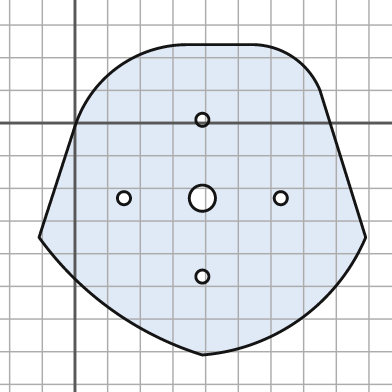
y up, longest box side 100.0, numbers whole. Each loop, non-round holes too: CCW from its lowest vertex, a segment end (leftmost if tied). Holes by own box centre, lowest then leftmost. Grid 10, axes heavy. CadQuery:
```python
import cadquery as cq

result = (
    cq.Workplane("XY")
    .moveTo(39.0, -71.0)
    .threePointArc((69.0, -60.0), (89.0, -35.0))
    .lineTo(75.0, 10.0)
    .threePointArc((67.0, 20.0), (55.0, 24.0))
    .lineTo(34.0, 24.0)
    .threePointArc((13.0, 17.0), (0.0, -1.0))
    .lineTo(-11.0, -35.0)
    .threePointArc((11.0, -57.0), (39.0, -71.0))
    .close()
    .moveTo(39.0, -47.0)
    .circle(2.0)
    .moveTo(15.0, -23.0)
    .circle(2.0)
    .moveTo(39.0, -23.0)
    .circle(4.0)
    .moveTo(63.0, -23.0)
    .circle(2.0)
    .moveTo(39.0, 1.0)
    .circle(2.0)
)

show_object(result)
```